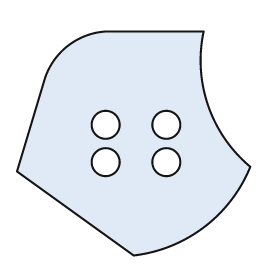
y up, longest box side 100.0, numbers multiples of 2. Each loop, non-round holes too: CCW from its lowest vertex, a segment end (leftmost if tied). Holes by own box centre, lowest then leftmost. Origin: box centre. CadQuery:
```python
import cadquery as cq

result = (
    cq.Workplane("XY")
    .moveTo(0.0, -48.0)
    .threePointArc((30.0, -36.0), (50.0, -10.0))
    .threePointArc((32.0, 16.0), (30.0, 48.0))
    .lineTo(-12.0, 48.0)
    .threePointArc((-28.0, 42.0), (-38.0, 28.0))
    .lineTo(-50.0, -12.0)
    .close()
    .moveTo(-12.0, -8.0)
    .circle(6.0)
    .moveTo(14.0, -8.0)
    .circle(6.0)
    .moveTo(-12.0, 8.0)
    .circle(6.0)
    .moveTo(14.0, 8.0)
    .circle(6.0)
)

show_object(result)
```